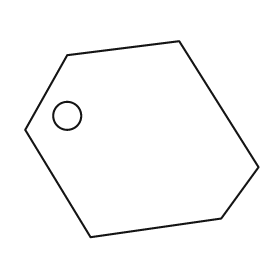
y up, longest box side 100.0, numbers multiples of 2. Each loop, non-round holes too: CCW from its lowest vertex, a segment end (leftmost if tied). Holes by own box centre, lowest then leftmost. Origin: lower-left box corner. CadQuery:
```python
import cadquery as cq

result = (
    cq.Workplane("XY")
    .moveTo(28.0, 0.0)
    .lineTo(84.0, 8.0)
    .lineTo(100.0, 30.0)
    .lineTo(66.0, 84.0)
    .lineTo(18.0, 78.0)
    .lineTo(0.0, 46.0)
    .close()
    .moveTo(18.0, 52.0)
    .circle(6.0)
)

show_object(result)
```